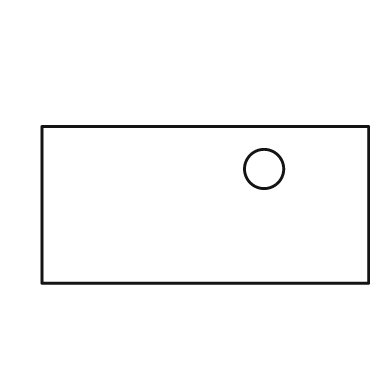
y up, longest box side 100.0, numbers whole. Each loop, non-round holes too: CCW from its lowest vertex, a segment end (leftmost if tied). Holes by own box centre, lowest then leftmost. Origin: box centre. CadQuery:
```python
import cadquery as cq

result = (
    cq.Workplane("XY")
    .moveTo(-50.0, -24.0)
    .lineTo(50.0, -24.0)
    .lineTo(50.0, 24.0)
    .lineTo(-50.0, 24.0)
    .close()
    .moveTo(18.0, 11.0)
    .circle(6.0)
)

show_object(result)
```